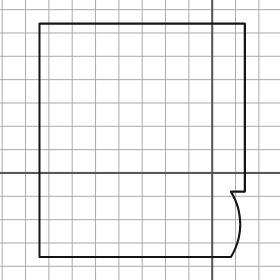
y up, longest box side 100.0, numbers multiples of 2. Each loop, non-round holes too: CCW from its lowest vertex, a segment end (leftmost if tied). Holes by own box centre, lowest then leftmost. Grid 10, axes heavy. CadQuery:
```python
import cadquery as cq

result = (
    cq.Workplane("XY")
    .moveTo(-74.0, -36.0)
    .lineTo(8.0, -36.0)
    .threePointArc((12.0, -22.0), (8.0, -8.0))
    .lineTo(14.0, -8.0)
    .lineTo(14.0, 64.0)
    .lineTo(-74.0, 64.0)
    .close()
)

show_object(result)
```